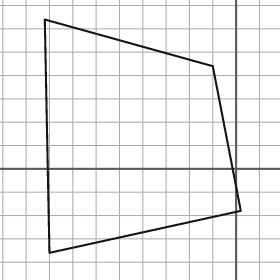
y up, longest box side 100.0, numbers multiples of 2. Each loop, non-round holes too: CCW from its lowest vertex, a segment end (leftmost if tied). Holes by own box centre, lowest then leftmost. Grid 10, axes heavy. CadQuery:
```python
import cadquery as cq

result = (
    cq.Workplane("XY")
    .moveTo(-80.0, -36.0)
    .lineTo(2.0, -18.0)
    .lineTo(-10.0, 44.0)
    .lineTo(-82.0, 64.0)
    .close()
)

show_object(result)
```